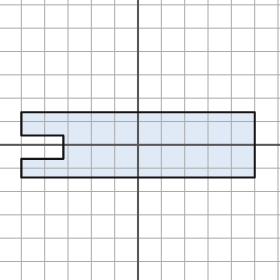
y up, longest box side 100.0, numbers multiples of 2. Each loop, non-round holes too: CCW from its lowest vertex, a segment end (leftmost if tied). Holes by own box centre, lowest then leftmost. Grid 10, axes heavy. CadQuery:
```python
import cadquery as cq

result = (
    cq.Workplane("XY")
    .moveTo(-50.0, -14.0)
    .lineTo(50.0, -14.0)
    .lineTo(50.0, 14.0)
    .lineTo(-50.0, 14.0)
    .lineTo(-50.0, 4.0)
    .lineTo(-32.0, 4.0)
    .lineTo(-32.0, -6.0)
    .lineTo(-50.0, -6.0)
    .close()
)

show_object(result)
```